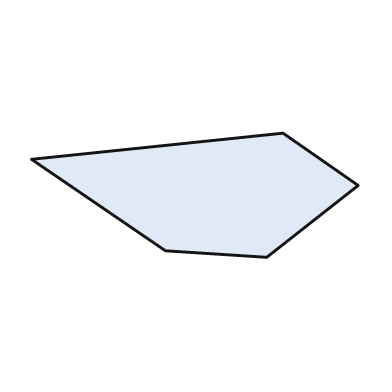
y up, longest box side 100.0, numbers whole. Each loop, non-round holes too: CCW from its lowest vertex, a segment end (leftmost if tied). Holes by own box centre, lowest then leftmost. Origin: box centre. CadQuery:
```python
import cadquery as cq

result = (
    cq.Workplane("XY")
    .moveTo(22.0, -19.0)
    .lineTo(50.0, 3.0)
    .lineTo(27.0, 19.0)
    .lineTo(-50.0, 11.0)
    .lineTo(-9.0, -17.0)
    .close()
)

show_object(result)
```